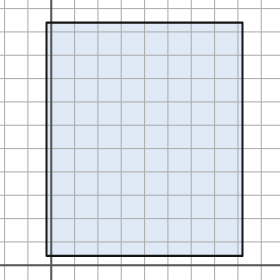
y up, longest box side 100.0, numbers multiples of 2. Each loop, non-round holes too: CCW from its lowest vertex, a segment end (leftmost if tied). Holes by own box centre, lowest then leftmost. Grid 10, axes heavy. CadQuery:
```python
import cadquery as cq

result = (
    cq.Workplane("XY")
    .moveTo(-2.0, 4.0)
    .lineTo(82.0, 4.0)
    .lineTo(82.0, 104.0)
    .lineTo(-2.0, 104.0)
    .close()
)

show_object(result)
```